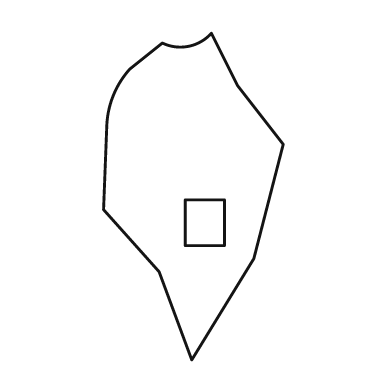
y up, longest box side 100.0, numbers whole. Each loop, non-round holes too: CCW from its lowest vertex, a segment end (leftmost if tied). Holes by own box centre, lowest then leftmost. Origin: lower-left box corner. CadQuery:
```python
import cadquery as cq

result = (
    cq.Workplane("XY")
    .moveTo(27.0, 0.0)
    .lineTo(46.0, 31.0)
    .lineTo(55.0, 66.0)
    .lineTo(41.0, 84.0)
    .lineTo(33.0, 100.0)
    .threePointArc((26.0, 96.0), (18.0, 97.0))
    .lineTo(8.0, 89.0)
    .threePointArc((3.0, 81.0), (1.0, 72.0))
    .lineTo(0.0, 46.0)
    .lineTo(17.0, 27.0)
    .close()
    .moveTo(25.0, 35.0)
    .lineTo(37.0, 35.0)
    .lineTo(37.0, 49.0)
    .lineTo(25.0, 49.0)
    .close()
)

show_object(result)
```